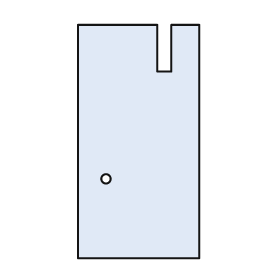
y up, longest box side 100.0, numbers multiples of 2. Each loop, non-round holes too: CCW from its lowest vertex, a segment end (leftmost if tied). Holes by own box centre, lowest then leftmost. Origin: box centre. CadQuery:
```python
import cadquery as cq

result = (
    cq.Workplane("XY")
    .moveTo(-26.0, -50.0)
    .lineTo(26.0, -50.0)
    .lineTo(26.0, 50.0)
    .lineTo(14.0, 50.0)
    .lineTo(14.0, 30.0)
    .lineTo(8.0, 30.0)
    .lineTo(8.0, 50.0)
    .lineTo(-26.0, 50.0)
    .close()
    .moveTo(-14.0, -16.0)
    .circle(2.0)
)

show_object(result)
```